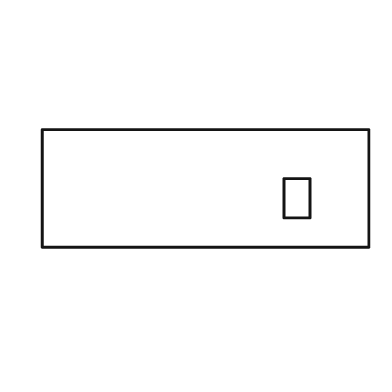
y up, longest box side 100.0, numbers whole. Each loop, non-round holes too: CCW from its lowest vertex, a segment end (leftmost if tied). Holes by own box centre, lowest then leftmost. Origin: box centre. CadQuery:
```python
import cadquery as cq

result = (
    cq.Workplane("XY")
    .moveTo(-50.0, -18.0)
    .lineTo(50.0, -18.0)
    .lineTo(50.0, 18.0)
    .lineTo(-50.0, 18.0)
    .close()
    .moveTo(24.0, -9.0)
    .lineTo(32.0, -9.0)
    .lineTo(32.0, 3.0)
    .lineTo(24.0, 3.0)
    .close()
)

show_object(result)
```